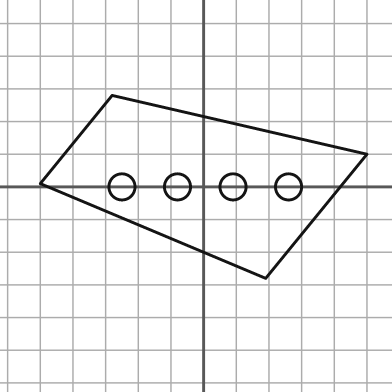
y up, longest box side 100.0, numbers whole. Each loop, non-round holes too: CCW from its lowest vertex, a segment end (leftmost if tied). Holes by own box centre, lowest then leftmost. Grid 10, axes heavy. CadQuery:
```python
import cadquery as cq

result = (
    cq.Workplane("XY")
    .moveTo(19.0, -28.0)
    .lineTo(50.0, 10.0)
    .lineTo(-28.0, 28.0)
    .lineTo(-50.0, 1.0)
    .close()
    .moveTo(-25.0, 0.0)
    .circle(4.0)
    .moveTo(-8.0, 0.0)
    .circle(4.0)
    .moveTo(9.0, 0.0)
    .circle(4.0)
    .moveTo(26.0, 0.0)
    .circle(4.0)
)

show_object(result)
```